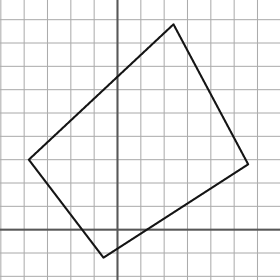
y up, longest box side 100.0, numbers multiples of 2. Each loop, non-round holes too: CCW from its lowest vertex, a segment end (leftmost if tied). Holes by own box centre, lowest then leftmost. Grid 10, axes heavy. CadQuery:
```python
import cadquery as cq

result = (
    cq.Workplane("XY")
    .moveTo(-6.0, -12.0)
    .lineTo(56.0, 28.0)
    .lineTo(24.0, 88.0)
    .lineTo(-38.0, 30.0)
    .close()
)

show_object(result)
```